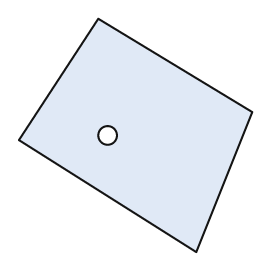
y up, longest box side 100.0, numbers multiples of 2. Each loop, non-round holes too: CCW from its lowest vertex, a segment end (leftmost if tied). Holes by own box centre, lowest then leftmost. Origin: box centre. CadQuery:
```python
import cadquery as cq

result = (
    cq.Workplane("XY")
    .moveTo(26.0, -50.0)
    .lineTo(50.0, 10.0)
    .lineTo(-16.0, 50.0)
    .lineTo(-50.0, -2.0)
    .close()
    .moveTo(-12.0, 0.0)
    .circle(4.0)
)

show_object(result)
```